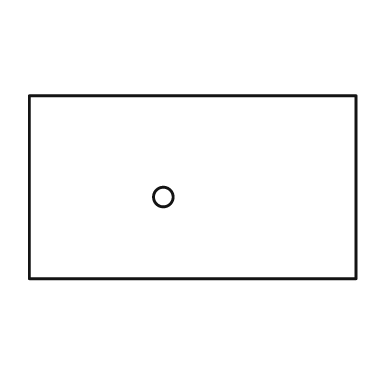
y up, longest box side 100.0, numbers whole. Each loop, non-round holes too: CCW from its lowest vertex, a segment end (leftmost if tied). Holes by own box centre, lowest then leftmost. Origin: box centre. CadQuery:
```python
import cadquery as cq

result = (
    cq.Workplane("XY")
    .moveTo(-50.0, -28.0)
    .lineTo(50.0, -28.0)
    .lineTo(50.0, 28.0)
    .lineTo(-50.0, 28.0)
    .close()
    .moveTo(-9.0, -3.0)
    .circle(3.0)
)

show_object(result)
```